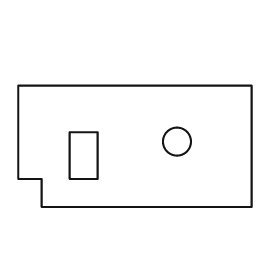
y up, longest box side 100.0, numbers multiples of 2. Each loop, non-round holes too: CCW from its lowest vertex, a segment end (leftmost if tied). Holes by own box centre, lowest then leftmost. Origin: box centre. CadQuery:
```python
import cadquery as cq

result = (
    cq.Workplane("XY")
    .moveTo(-40.0, -26.0)
    .lineTo(50.0, -26.0)
    .lineTo(50.0, 26.0)
    .lineTo(-50.0, 26.0)
    .lineTo(-50.0, -14.0)
    .lineTo(-40.0, -14.0)
    .close()
    .moveTo(-28.0, -14.0)
    .lineTo(-16.0, -14.0)
    .lineTo(-16.0, 6.0)
    .lineTo(-28.0, 6.0)
    .close()
    .moveTo(18.0, 2.0)
    .circle(6.0)
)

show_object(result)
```